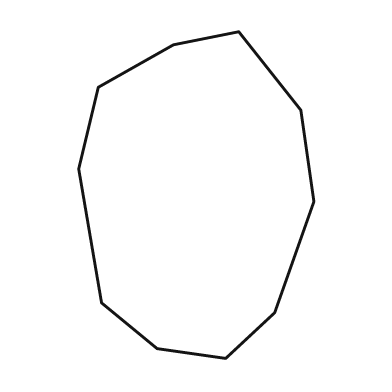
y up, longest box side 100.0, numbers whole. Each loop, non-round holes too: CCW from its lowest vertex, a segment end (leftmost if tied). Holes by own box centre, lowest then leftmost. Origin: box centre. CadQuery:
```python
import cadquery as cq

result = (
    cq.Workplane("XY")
    .moveTo(9.0, -50.0)
    .lineTo(24.0, -36.0)
    .lineTo(36.0, -2.0)
    .lineTo(32.0, 26.0)
    .lineTo(13.0, 50.0)
    .lineTo(-7.0, 46.0)
    .lineTo(-30.0, 33.0)
    .lineTo(-36.0, 8.0)
    .lineTo(-29.0, -33.0)
    .lineTo(-12.0, -47.0)
    .close()
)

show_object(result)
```